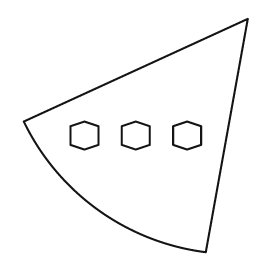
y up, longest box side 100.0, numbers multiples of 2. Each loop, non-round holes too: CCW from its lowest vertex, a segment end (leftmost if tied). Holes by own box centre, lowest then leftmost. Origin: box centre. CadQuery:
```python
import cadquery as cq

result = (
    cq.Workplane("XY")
    .moveTo(30.0, -50.0)
    .lineTo(48.0, 50.0)
    .lineTo(-48.0, 6.0)
    .threePointArc((-16.0, -32.0), (30.0, -50.0))
    .close()
    .moveTo(-22.0, -6.0)
    .lineTo(-16.0, -4.0)
    .lineTo(-16.0, 4.0)
    .lineTo(-22.0, 6.0)
    .lineTo(-28.0, 4.0)
    .lineTo(-28.0, -4.0)
    .close()
    .moveTo(0.0, -6.0)
    .lineTo(6.0, -4.0)
    .lineTo(6.0, 4.0)
    .lineTo(0.0, 6.0)
    .lineTo(-6.0, 4.0)
    .lineTo(-6.0, -4.0)
    .close()
    .moveTo(22.0, -6.0)
    .lineTo(28.0, -4.0)
    .lineTo(28.0, 4.0)
    .lineTo(22.0, 6.0)
    .lineTo(16.0, 4.0)
    .lineTo(16.0, -4.0)
    .close()
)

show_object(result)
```